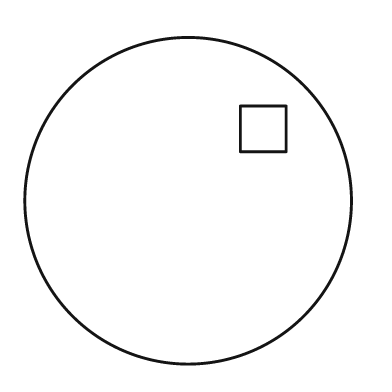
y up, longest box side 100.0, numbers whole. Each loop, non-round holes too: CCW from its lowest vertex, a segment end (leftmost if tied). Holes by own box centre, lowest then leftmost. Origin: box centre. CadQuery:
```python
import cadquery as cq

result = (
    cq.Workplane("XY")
    .moveTo(0.0, 0.0)
    .circle(50.0)
    .moveTo(16.0, 15.0)
    .lineTo(30.0, 15.0)
    .lineTo(30.0, 29.0)
    .lineTo(16.0, 29.0)
    .close()
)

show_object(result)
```